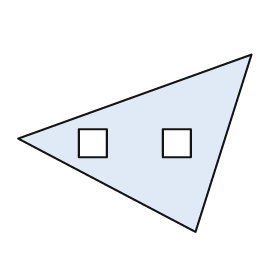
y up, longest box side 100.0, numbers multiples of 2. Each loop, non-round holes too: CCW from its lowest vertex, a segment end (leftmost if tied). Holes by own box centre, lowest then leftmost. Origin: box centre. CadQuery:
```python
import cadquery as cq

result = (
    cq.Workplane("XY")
    .moveTo(26.0, -38.0)
    .lineTo(50.0, 38.0)
    .lineTo(-50.0, 2.0)
    .close()
    .moveTo(-24.0, -6.0)
    .lineTo(-12.0, -6.0)
    .lineTo(-12.0, 6.0)
    .lineTo(-24.0, 6.0)
    .close()
    .moveTo(12.0, -6.0)
    .lineTo(24.0, -6.0)
    .lineTo(24.0, 6.0)
    .lineTo(12.0, 6.0)
    .close()
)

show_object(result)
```